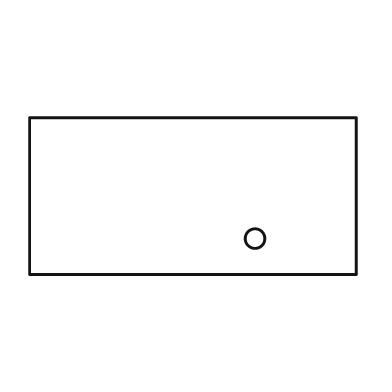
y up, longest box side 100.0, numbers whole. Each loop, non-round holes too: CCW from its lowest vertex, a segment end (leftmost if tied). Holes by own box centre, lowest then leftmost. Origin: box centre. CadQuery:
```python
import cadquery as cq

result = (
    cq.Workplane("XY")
    .moveTo(-50.0, -24.0)
    .lineTo(50.0, -24.0)
    .lineTo(50.0, 24.0)
    .lineTo(-50.0, 24.0)
    .close()
    .moveTo(19.0, -13.0)
    .circle(3.0)
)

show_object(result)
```